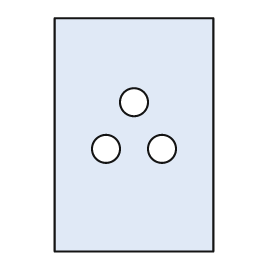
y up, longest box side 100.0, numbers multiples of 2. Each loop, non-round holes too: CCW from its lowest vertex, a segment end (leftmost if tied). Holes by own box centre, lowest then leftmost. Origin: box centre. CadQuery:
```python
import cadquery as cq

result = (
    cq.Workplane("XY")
    .moveTo(-34.0, -50.0)
    .lineTo(34.0, -50.0)
    .lineTo(34.0, 50.0)
    .lineTo(-34.0, 50.0)
    .close()
    .moveTo(-12.0, -6.0)
    .circle(6.0)
    .moveTo(12.0, -6.0)
    .circle(6.0)
    .moveTo(0.0, 14.0)
    .circle(6.0)
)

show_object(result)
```